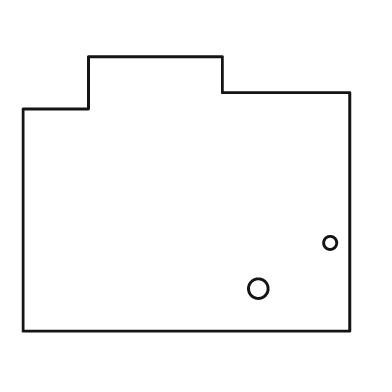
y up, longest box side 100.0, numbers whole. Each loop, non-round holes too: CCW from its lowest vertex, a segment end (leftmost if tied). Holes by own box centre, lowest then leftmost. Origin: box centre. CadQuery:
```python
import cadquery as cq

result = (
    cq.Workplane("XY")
    .moveTo(-50.0, -42.0)
    .lineTo(50.0, -42.0)
    .lineTo(50.0, 31.0)
    .lineTo(11.0, 31.0)
    .lineTo(11.0, 42.0)
    .lineTo(-30.0, 42.0)
    .lineTo(-30.0, 26.0)
    .lineTo(-50.0, 26.0)
    .close()
    .moveTo(22.0, -29.0)
    .circle(3.0)
    .moveTo(44.0, -15.0)
    .circle(2.0)
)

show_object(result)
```